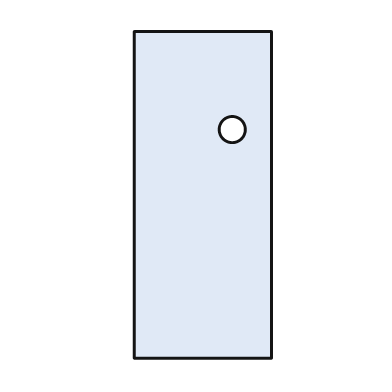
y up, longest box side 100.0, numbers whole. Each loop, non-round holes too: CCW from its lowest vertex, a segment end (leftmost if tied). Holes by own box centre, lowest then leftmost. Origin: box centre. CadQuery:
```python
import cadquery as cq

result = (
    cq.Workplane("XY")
    .moveTo(-21.0, -50.0)
    .lineTo(21.0, -50.0)
    .lineTo(21.0, 50.0)
    .lineTo(-21.0, 50.0)
    .close()
    .moveTo(9.0, 20.0)
    .circle(4.0)
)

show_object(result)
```